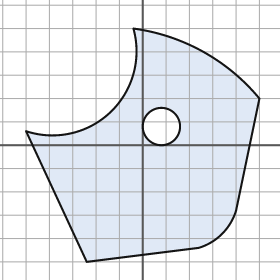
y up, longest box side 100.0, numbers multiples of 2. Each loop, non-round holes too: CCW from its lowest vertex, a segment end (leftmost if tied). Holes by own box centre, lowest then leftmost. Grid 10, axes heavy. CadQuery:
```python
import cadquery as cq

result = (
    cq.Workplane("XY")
    .moveTo(-24.0, -50.0)
    .lineTo(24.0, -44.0)
    .threePointArc((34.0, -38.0), (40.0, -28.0))
    .lineTo(50.0, 20.0)
    .threePointArc((26.0, 40.0), (-4.0, 50.0))
    .threePointArc((-14.0, 14.0), (-50.0, 6.0))
    .close()
    .moveTo(8.0, 8.0)
    .circle(8.0)
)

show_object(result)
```